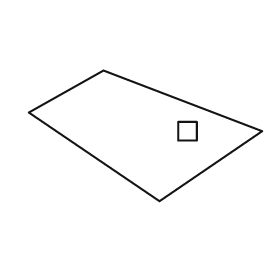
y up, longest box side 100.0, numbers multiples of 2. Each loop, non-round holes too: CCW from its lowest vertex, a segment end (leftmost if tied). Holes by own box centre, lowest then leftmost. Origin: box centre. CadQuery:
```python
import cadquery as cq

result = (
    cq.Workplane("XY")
    .moveTo(6.0, -28.0)
    .lineTo(50.0, 2.0)
    .lineTo(-18.0, 28.0)
    .lineTo(-50.0, 10.0)
    .close()
    .moveTo(14.0, -2.0)
    .lineTo(22.0, -2.0)
    .lineTo(22.0, 6.0)
    .lineTo(14.0, 6.0)
    .close()
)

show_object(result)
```